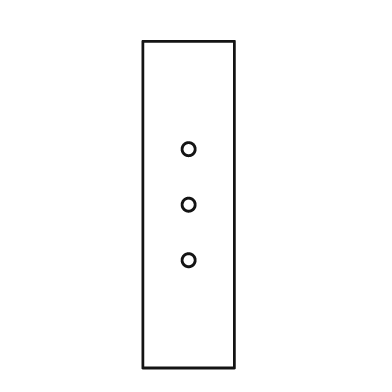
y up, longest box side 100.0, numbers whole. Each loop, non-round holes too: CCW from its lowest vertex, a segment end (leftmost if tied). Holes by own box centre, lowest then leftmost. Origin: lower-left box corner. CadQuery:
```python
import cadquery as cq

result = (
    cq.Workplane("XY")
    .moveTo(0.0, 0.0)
    .lineTo(28.0, 0.0)
    .lineTo(28.0, 100.0)
    .lineTo(0.0, 100.0)
    .close()
    .moveTo(14.0, 33.0)
    .circle(2.0)
    .moveTo(14.0, 50.0)
    .circle(2.0)
    .moveTo(14.0, 67.0)
    .circle(2.0)
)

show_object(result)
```